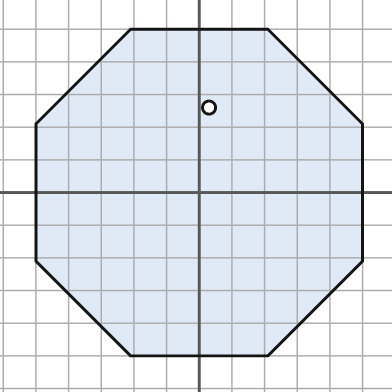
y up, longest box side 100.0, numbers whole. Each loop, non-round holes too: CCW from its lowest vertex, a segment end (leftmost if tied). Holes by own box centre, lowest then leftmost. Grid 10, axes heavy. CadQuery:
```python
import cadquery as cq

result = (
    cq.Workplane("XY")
    .moveTo(-21.0, -50.0)
    .lineTo(21.0, -50.0)
    .lineTo(50.0, -21.0)
    .lineTo(50.0, 21.0)
    .lineTo(21.0, 50.0)
    .lineTo(-21.0, 50.0)
    .lineTo(-50.0, 21.0)
    .lineTo(-50.0, -21.0)
    .close()
    .moveTo(3.0, 26.0)
    .circle(2.0)
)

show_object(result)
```